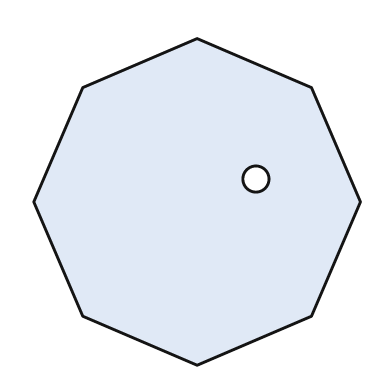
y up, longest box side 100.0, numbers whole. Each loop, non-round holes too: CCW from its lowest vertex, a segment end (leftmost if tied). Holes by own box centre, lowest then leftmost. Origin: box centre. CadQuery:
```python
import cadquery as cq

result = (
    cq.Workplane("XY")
    .moveTo(0.0, -50.0)
    .lineTo(35.0, -35.0)
    .lineTo(50.0, 0.0)
    .lineTo(35.0, 35.0)
    .lineTo(0.0, 50.0)
    .lineTo(-35.0, 35.0)
    .lineTo(-50.0, 0.0)
    .lineTo(-35.0, -35.0)
    .close()
    .moveTo(18.0, 7.0)
    .circle(4.0)
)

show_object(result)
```